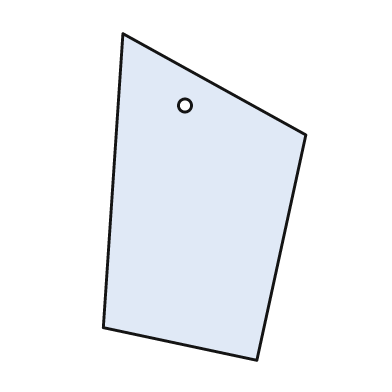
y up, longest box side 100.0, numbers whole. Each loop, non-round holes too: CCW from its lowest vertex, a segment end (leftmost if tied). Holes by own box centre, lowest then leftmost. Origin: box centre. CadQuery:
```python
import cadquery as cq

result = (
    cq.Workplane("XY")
    .moveTo(16.0, -50.0)
    .lineTo(31.0, 19.0)
    .lineTo(-25.0, 50.0)
    .lineTo(-31.0, -40.0)
    .close()
    .moveTo(-6.0, 28.0)
    .circle(2.0)
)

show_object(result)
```